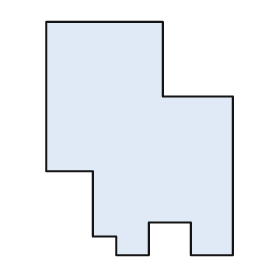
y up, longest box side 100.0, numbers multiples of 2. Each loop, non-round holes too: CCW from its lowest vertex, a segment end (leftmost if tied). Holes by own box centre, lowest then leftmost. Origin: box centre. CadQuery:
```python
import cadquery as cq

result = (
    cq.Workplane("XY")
    .moveTo(-10.0, -50.0)
    .lineTo(4.0, -50.0)
    .lineTo(4.0, -36.0)
    .lineTo(22.0, -36.0)
    .lineTo(22.0, -50.0)
    .lineTo(40.0, -50.0)
    .lineTo(40.0, 18.0)
    .lineTo(10.0, 18.0)
    .lineTo(10.0, 50.0)
    .lineTo(-40.0, 50.0)
    .lineTo(-40.0, -14.0)
    .lineTo(-20.0, -14.0)
    .lineTo(-20.0, -42.0)
    .lineTo(-10.0, -42.0)
    .close()
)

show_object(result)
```